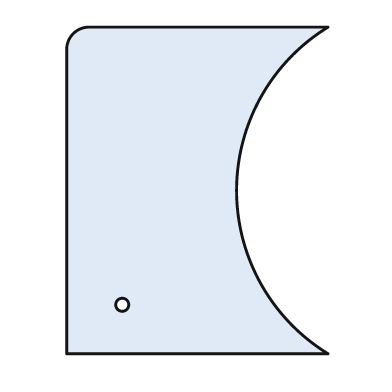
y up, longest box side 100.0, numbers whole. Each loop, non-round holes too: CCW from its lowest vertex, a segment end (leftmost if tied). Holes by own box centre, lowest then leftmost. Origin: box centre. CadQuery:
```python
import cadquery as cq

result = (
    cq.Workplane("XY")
    .moveTo(-40.0, -50.0)
    .lineTo(40.0, -50.0)
    .threePointArc((12.0, 0.0), (40.0, 50.0))
    .lineTo(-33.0, 50.0)
    .threePointArc((-38.0, 48.0), (-40.0, 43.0))
    .close()
    .moveTo(-23.0, -35.0)
    .circle(2.0)
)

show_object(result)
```